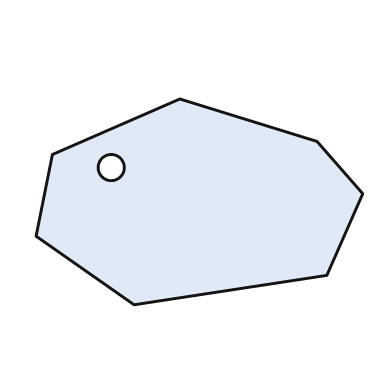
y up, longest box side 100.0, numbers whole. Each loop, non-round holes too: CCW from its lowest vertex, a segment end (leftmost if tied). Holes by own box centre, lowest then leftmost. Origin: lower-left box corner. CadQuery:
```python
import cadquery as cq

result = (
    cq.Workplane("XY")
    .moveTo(30.0, 0.0)
    .lineTo(89.0, 9.0)
    .lineTo(100.0, 34.0)
    .lineTo(86.0, 50.0)
    .lineTo(44.0, 63.0)
    .lineTo(5.0, 46.0)
    .lineTo(0.0, 21.0)
    .close()
    .moveTo(23.0, 42.0)
    .circle(4.0)
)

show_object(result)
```